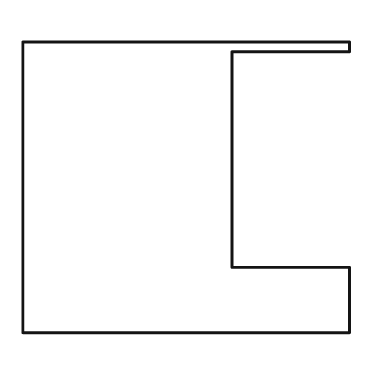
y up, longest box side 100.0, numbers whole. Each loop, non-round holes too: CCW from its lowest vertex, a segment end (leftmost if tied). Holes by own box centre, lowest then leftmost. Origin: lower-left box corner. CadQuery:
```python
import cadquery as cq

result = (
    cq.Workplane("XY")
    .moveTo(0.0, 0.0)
    .lineTo(100.0, 0.0)
    .lineTo(100.0, 20.0)
    .lineTo(64.0, 20.0)
    .lineTo(64.0, 86.0)
    .lineTo(100.0, 86.0)
    .lineTo(100.0, 89.0)
    .lineTo(0.0, 89.0)
    .close()
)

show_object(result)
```